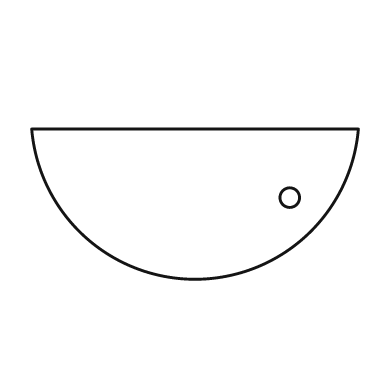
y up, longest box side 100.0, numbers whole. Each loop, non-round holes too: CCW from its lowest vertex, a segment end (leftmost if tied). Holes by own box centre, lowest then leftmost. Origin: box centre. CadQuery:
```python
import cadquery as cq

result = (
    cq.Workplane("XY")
    .moveTo(-50.0, 23.0)
    .threePointArc((0.0, -23.0), (50.0, 23.0))
    .close()
    .moveTo(29.0, 2.0)
    .circle(3.0)
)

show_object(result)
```